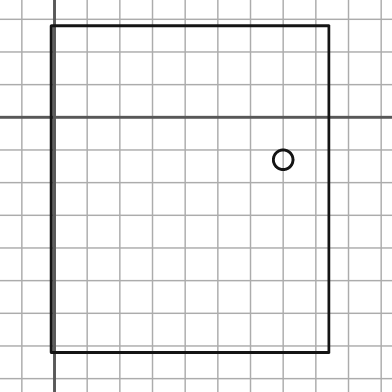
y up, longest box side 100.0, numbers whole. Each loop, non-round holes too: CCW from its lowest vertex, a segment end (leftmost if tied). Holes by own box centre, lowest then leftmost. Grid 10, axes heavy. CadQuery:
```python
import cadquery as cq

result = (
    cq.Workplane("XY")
    .moveTo(-1.0, -72.0)
    .lineTo(84.0, -72.0)
    .lineTo(84.0, 28.0)
    .lineTo(-1.0, 28.0)
    .close()
    .moveTo(70.0, -13.0)
    .circle(3.0)
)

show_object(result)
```